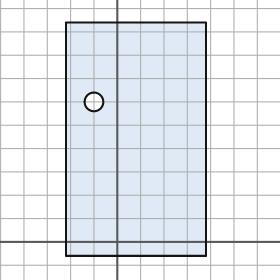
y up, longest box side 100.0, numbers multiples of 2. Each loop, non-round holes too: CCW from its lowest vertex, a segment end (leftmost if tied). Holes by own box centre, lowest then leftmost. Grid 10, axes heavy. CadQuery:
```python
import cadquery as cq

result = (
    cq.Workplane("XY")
    .moveTo(-22.0, -6.0)
    .lineTo(38.0, -6.0)
    .lineTo(38.0, 94.0)
    .lineTo(-22.0, 94.0)
    .close()
    .moveTo(-10.0, 60.0)
    .circle(4.0)
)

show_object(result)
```